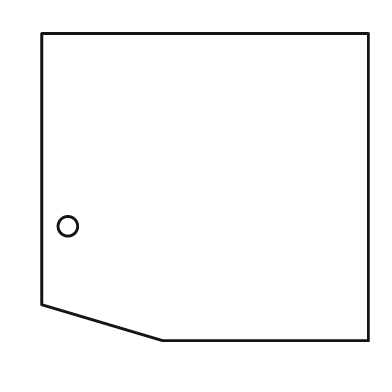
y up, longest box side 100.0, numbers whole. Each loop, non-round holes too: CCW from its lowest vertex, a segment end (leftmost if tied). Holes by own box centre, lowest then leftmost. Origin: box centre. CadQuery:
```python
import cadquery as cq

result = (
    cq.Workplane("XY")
    .moveTo(-13.0, -47.0)
    .lineTo(50.0, -47.0)
    .lineTo(50.0, 47.0)
    .lineTo(-50.0, 47.0)
    .lineTo(-50.0, -36.0)
    .close()
    .moveTo(-42.0, -12.0)
    .circle(3.0)
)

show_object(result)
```